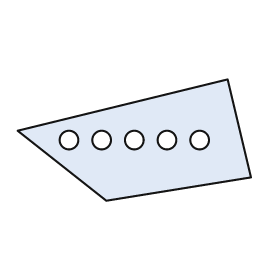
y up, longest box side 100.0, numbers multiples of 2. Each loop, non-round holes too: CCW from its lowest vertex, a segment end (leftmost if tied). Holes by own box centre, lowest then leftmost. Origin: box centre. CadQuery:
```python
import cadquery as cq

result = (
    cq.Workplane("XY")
    .moveTo(-12.0, -26.0)
    .lineTo(50.0, -16.0)
    .lineTo(40.0, 26.0)
    .lineTo(-50.0, 4.0)
    .close()
    .moveTo(-28.0, 0.0)
    .circle(4.0)
    .moveTo(-14.0, 0.0)
    .circle(4.0)
    .moveTo(0.0, 0.0)
    .circle(4.0)
    .moveTo(14.0, 0.0)
    .circle(4.0)
    .moveTo(28.0, 0.0)
    .circle(4.0)
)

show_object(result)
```